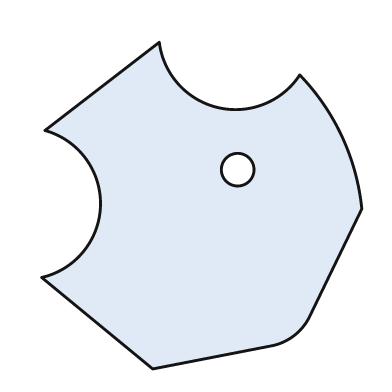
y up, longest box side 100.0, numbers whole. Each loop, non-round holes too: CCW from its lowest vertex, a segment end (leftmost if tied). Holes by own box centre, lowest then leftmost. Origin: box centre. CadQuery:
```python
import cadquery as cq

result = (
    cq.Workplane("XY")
    .moveTo(-15.0, -50.0)
    .lineTo(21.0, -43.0)
    .threePointArc((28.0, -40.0), (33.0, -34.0))
    .lineTo(49.0, -1.0)
    .threePointArc((43.0, 21.0), (30.0, 40.0))
    .threePointArc((5.0, 30.0), (-13.0, 50.0))
    .lineTo(-48.0, 23.0)
    .threePointArc((-31.0, 0.0), (-49.0, -22.0))
    .close()
    .moveTo(11.0, 11.0)
    .circle(5.0)
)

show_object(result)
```